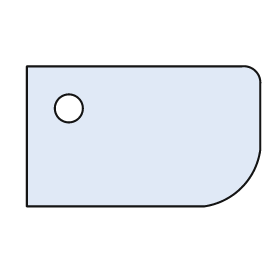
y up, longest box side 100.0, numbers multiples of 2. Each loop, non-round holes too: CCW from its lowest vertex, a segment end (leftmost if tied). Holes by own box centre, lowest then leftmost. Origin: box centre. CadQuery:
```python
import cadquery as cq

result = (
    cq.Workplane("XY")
    .moveTo(-50.0, -30.0)
    .lineTo(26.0, -30.0)
    .threePointArc((42.0, -22.0), (50.0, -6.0))
    .lineTo(50.0, 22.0)
    .threePointArc((48.0, 28.0), (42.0, 30.0))
    .lineTo(-50.0, 30.0)
    .close()
    .moveTo(-32.0, 12.0)
    .circle(6.0)
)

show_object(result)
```